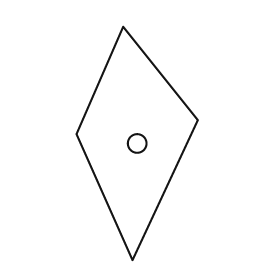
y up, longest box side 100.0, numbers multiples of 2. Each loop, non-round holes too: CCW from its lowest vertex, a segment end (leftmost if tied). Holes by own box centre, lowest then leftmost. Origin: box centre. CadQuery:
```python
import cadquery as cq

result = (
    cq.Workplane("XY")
    .moveTo(-2.0, -50.0)
    .lineTo(26.0, 10.0)
    .lineTo(-6.0, 50.0)
    .lineTo(-26.0, 4.0)
    .close()
    .moveTo(0.0, 0.0)
    .circle(4.0)
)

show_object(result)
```